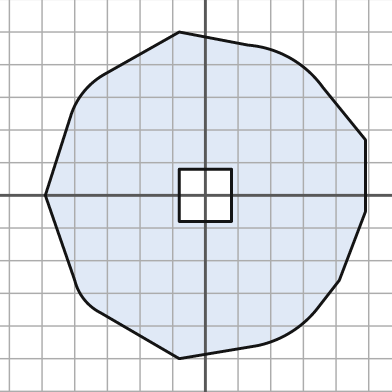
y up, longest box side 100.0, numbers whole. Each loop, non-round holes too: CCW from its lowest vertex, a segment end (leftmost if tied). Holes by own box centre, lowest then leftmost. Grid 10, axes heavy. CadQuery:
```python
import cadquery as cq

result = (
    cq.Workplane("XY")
    .moveTo(-8.0, -50.0)
    .lineTo(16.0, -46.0)
    .threePointArc((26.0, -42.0), (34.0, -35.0))
    .lineTo(41.0, -26.0)
    .lineTo(49.0, -5.0)
    .lineTo(49.0, 17.0)
    .lineTo(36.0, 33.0)
    .threePointArc((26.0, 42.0), (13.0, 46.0))
    .lineTo(-8.0, 50.0)
    .lineTo(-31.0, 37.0)
    .threePointArc((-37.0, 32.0), (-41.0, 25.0))
    .lineTo(-49.0, 0.0)
    .lineTo(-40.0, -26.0)
    .threePointArc((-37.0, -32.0), (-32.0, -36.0))
    .close()
    .moveTo(-8.0, -8.0)
    .lineTo(8.0, -8.0)
    .lineTo(8.0, 8.0)
    .lineTo(-8.0, 8.0)
    .close()
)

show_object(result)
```